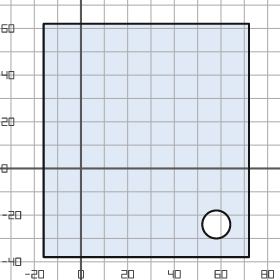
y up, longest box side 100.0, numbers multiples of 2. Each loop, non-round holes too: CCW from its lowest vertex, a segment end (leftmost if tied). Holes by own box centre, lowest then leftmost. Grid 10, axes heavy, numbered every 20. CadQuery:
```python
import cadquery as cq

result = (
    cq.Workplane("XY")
    .moveTo(-16.0, -38.0)
    .lineTo(72.0, -38.0)
    .lineTo(72.0, 62.0)
    .lineTo(-16.0, 62.0)
    .close()
    .moveTo(58.0, -24.0)
    .circle(6.0)
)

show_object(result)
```